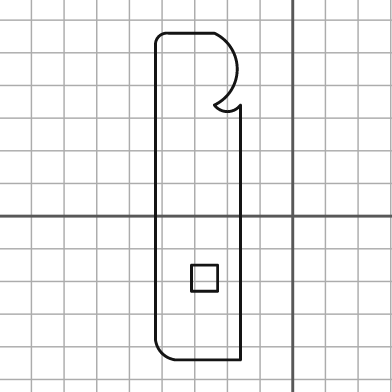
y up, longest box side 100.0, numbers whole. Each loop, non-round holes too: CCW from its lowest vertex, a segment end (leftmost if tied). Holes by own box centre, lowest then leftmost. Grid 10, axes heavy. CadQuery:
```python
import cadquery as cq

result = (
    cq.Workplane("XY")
    .moveTo(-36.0, -44.0)
    .lineTo(-16.0, -44.0)
    .lineTo(-16.0, 34.0)
    .threePointArc((-20.0, 32.0), (-24.0, 34.0))
    .threePointArc((-17.0, 45.0), (-24.0, 56.0))
    .lineTo(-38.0, 56.0)
    .threePointArc((-41.0, 55.0), (-42.0, 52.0))
    .lineTo(-42.0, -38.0)
    .threePointArc((-40.0, -42.0), (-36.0, -44.0))
    .close()
    .moveTo(-31.0, -23.0)
    .lineTo(-23.0, -23.0)
    .lineTo(-23.0, -15.0)
    .lineTo(-31.0, -15.0)
    .close()
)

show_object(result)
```